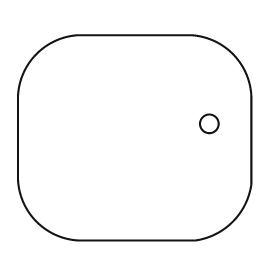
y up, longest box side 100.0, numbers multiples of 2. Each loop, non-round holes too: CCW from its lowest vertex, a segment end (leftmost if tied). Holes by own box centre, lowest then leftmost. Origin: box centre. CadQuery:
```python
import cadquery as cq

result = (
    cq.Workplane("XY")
    .moveTo(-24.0, -44.0)
    .lineTo(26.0, -44.0)
    .threePointArc((42.0, -36.0), (50.0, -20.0))
    .lineTo(50.0, 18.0)
    .threePointArc((42.0, 36.0), (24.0, 44.0))
    .lineTo(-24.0, 44.0)
    .threePointArc((-42.0, 36.0), (-50.0, 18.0))
    .lineTo(-50.0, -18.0)
    .threePointArc((-42.0, -36.0), (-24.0, -44.0))
    .close()
    .moveTo(32.0, 6.0)
    .circle(4.0)
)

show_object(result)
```